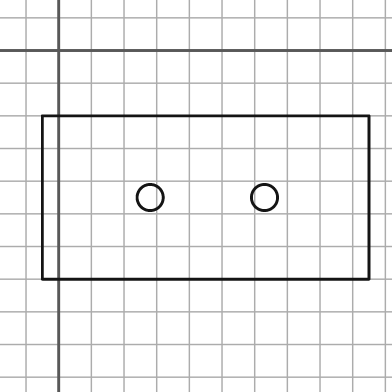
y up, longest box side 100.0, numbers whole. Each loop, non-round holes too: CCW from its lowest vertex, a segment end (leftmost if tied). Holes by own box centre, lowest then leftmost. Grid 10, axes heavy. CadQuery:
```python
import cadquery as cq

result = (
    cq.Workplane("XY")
    .moveTo(-5.0, -70.0)
    .lineTo(95.0, -70.0)
    .lineTo(95.0, -20.0)
    .lineTo(-5.0, -20.0)
    .close()
    .moveTo(28.0, -45.0)
    .circle(4.0)
    .moveTo(63.0, -45.0)
    .circle(4.0)
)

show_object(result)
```